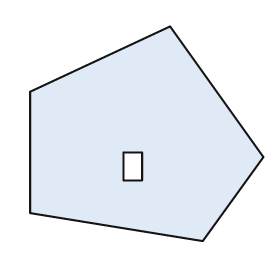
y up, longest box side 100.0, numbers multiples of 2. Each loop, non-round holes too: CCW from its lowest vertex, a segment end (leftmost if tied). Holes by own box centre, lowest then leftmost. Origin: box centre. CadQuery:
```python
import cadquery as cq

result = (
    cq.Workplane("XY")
    .moveTo(24.0, -46.0)
    .lineTo(50.0, -10.0)
    .lineTo(10.0, 46.0)
    .lineTo(-50.0, 18.0)
    .lineTo(-50.0, -34.0)
    .close()
    .moveTo(-10.0, -20.0)
    .lineTo(-2.0, -20.0)
    .lineTo(-2.0, -8.0)
    .lineTo(-10.0, -8.0)
    .close()
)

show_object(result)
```